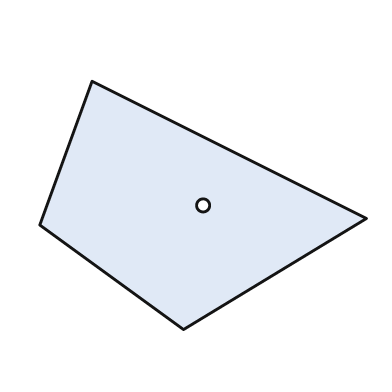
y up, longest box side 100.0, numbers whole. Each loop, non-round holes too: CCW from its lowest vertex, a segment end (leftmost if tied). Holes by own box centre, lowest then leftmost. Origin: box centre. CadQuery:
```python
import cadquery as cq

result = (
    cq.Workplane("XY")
    .moveTo(-6.0, -38.0)
    .lineTo(50.0, -4.0)
    .lineTo(-34.0, 38.0)
    .lineTo(-50.0, -6.0)
    .close()
    .moveTo(0.0, 0.0)
    .circle(2.0)
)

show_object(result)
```